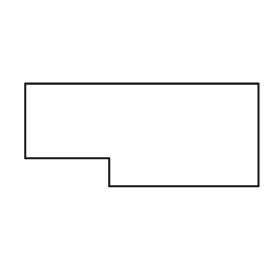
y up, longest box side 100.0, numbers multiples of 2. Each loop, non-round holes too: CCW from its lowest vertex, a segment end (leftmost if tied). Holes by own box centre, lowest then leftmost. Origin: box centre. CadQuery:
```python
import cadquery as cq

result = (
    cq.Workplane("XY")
    .moveTo(-14.0, -22.0)
    .lineTo(50.0, -22.0)
    .lineTo(50.0, 22.0)
    .lineTo(-50.0, 22.0)
    .lineTo(-50.0, -10.0)
    .lineTo(-14.0, -10.0)
    .close()
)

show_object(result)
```